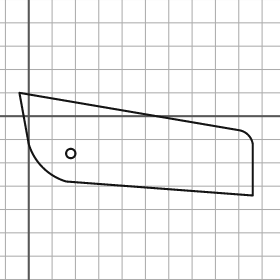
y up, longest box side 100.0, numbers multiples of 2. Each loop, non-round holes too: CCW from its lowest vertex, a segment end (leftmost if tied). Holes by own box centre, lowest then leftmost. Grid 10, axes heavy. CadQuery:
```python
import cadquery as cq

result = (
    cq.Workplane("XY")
    .moveTo(96.0, -34.0)
    .lineTo(96.0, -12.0)
    .threePointArc((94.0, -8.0), (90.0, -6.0))
    .lineTo(-4.0, 10.0)
    .lineTo(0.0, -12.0)
    .threePointArc((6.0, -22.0), (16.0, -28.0))
    .close()
    .moveTo(18.0, -16.0)
    .circle(2.0)
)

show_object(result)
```